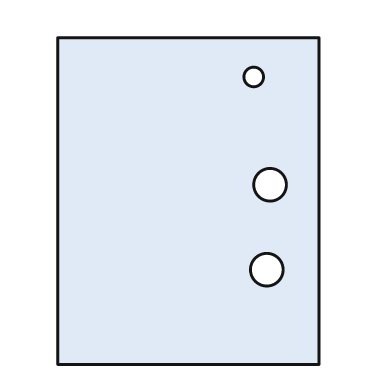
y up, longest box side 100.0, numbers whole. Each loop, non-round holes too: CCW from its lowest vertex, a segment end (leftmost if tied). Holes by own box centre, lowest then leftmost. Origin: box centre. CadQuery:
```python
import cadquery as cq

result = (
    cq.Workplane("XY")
    .moveTo(-40.0, -50.0)
    .lineTo(40.0, -50.0)
    .lineTo(40.0, 50.0)
    .lineTo(-40.0, 50.0)
    .close()
    .moveTo(24.0, -21.0)
    .circle(5.0)
    .moveTo(25.0, 5.0)
    .circle(5.0)
    .moveTo(20.0, 38.0)
    .circle(3.0)
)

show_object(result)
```